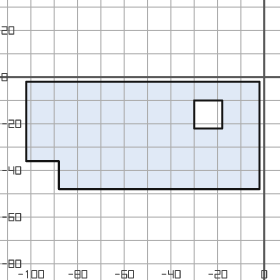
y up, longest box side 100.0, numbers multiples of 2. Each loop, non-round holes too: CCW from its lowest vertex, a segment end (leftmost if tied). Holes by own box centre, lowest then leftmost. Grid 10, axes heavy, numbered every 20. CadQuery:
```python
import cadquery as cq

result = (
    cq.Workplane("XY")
    .moveTo(-88.0, -48.0)
    .lineTo(-2.0, -48.0)
    .lineTo(-2.0, -2.0)
    .lineTo(-102.0, -2.0)
    .lineTo(-102.0, -36.0)
    .lineTo(-88.0, -36.0)
    .close()
    .moveTo(-30.0, -22.0)
    .lineTo(-18.0, -22.0)
    .lineTo(-18.0, -10.0)
    .lineTo(-30.0, -10.0)
    .close()
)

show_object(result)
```